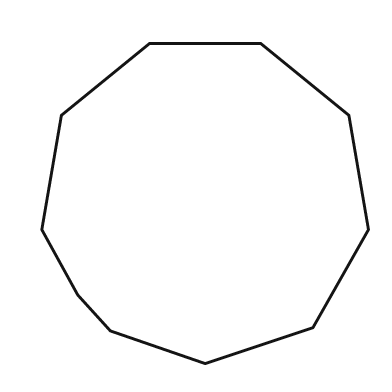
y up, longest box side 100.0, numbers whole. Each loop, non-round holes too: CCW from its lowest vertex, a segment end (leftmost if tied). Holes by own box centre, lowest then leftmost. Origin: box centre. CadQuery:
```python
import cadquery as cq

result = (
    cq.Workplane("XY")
    .moveTo(0.0, -49.0)
    .lineTo(33.0, -38.0)
    .lineTo(50.0, -8.0)
    .lineTo(44.0, 27.0)
    .lineTo(17.0, 49.0)
    .lineTo(-17.0, 49.0)
    .lineTo(-44.0, 27.0)
    .lineTo(-50.0, -8.0)
    .lineTo(-39.0, -28.0)
    .lineTo(-29.0, -39.0)
    .close()
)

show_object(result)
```